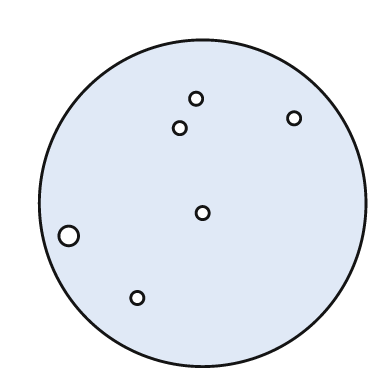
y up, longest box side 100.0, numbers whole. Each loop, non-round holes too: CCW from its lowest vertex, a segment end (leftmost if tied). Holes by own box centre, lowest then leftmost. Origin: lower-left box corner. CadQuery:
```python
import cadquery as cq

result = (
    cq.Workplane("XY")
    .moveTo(50.0, 50.0)
    .circle(50.0)
    .moveTo(30.0, 21.0)
    .circle(2.0)
    .moveTo(9.0, 40.0)
    .circle(3.0)
    .moveTo(50.0, 47.0)
    .circle(2.0)
    .moveTo(43.0, 73.0)
    .circle(2.0)
    .moveTo(78.0, 76.0)
    .circle(2.0)
    .moveTo(48.0, 82.0)
    .circle(2.0)
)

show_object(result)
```